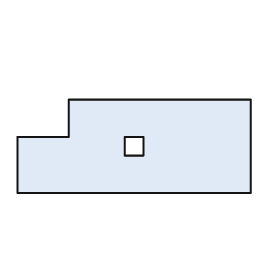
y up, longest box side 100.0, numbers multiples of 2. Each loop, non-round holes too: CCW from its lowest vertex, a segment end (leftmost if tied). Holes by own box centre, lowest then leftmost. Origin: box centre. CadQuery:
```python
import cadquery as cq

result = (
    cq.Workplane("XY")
    .moveTo(-50.0, -20.0)
    .lineTo(50.0, -20.0)
    .lineTo(50.0, 20.0)
    .lineTo(-28.0, 20.0)
    .lineTo(-28.0, 4.0)
    .lineTo(-50.0, 4.0)
    .close()
    .moveTo(-4.0, -4.0)
    .lineTo(4.0, -4.0)
    .lineTo(4.0, 4.0)
    .lineTo(-4.0, 4.0)
    .close()
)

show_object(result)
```